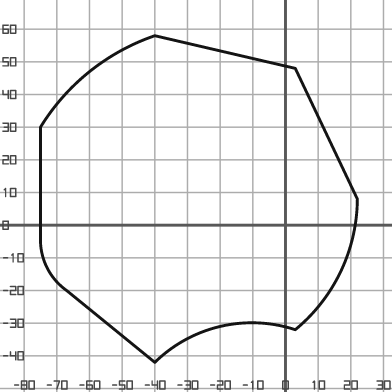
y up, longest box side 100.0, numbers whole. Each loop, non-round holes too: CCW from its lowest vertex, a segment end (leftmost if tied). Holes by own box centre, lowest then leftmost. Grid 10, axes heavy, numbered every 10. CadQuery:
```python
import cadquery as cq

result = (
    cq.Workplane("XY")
    .moveTo(-40.0, -42.0)
    .threePointArc((-20.0, -31.0), (3.0, -32.0))
    .threePointArc((17.0, -14.0), (22.0, 8.0))
    .lineTo(3.0, 48.0)
    .lineTo(-40.0, 58.0)
    .threePointArc((-60.0, 47.0), (-75.0, 30.0))
    .lineTo(-75.0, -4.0)
    .threePointArc((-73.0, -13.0), (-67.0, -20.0))
    .close()
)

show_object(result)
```